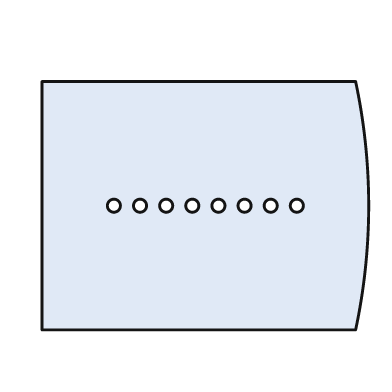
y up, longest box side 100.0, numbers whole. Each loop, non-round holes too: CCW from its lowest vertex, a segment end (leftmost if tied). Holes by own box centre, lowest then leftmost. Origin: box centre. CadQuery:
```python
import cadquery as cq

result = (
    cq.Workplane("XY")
    .moveTo(-50.0, -38.0)
    .lineTo(46.0, -38.0)
    .threePointArc((50.0, 0.0), (46.0, 38.0))
    .lineTo(-50.0, 38.0)
    .close()
    .moveTo(-28.0, 0.0)
    .circle(2.0)
    .moveTo(-20.0, 0.0)
    .circle(2.0)
    .moveTo(-12.0, 0.0)
    .circle(2.0)
    .moveTo(-4.0, 0.0)
    .circle(2.0)
    .moveTo(4.0, 0.0)
    .circle(2.0)
    .moveTo(12.0, 0.0)
    .circle(2.0)
    .moveTo(20.0, 0.0)
    .circle(2.0)
    .moveTo(28.0, 0.0)
    .circle(2.0)
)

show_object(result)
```